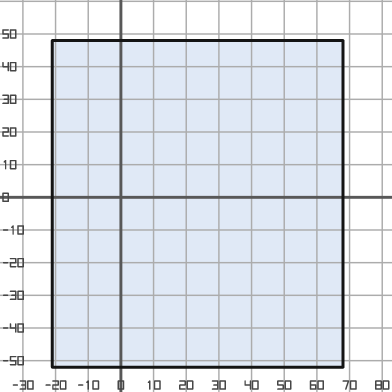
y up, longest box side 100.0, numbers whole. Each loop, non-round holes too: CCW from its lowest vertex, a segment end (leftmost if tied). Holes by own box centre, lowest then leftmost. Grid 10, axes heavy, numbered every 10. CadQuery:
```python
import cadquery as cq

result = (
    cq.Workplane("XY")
    .moveTo(-21.0, -52.0)
    .lineTo(68.0, -52.0)
    .lineTo(68.0, 48.0)
    .lineTo(-21.0, 48.0)
    .close()
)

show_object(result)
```